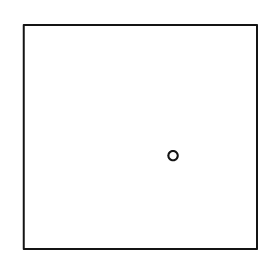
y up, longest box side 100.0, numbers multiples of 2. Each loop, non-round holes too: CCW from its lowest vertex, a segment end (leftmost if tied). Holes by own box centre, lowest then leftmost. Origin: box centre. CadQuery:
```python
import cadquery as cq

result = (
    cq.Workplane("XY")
    .moveTo(-50.0, -48.0)
    .lineTo(50.0, -48.0)
    .lineTo(50.0, 48.0)
    .lineTo(-50.0, 48.0)
    .close()
    .moveTo(14.0, -8.0)
    .circle(2.0)
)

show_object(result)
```